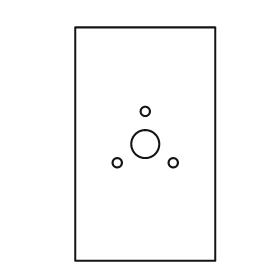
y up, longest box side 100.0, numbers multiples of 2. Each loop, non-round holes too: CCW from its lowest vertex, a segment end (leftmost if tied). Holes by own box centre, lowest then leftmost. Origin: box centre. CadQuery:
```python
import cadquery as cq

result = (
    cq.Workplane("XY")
    .moveTo(-30.0, -50.0)
    .lineTo(30.0, -50.0)
    .lineTo(30.0, 50.0)
    .lineTo(-30.0, 50.0)
    .close()
    .moveTo(-12.0, -8.0)
    .circle(2.0)
    .moveTo(12.0, -8.0)
    .circle(2.0)
    .moveTo(0.0, 0.0)
    .circle(6.0)
    .moveTo(0.0, 14.0)
    .circle(2.0)
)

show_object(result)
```